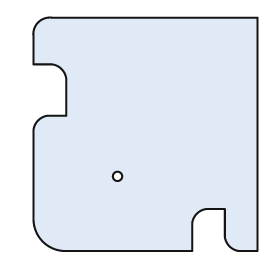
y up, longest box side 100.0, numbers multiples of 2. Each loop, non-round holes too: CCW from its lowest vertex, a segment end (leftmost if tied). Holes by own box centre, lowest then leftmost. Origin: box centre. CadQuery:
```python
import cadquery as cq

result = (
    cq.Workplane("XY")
    .moveTo(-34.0, -50.0)
    .lineTo(20.0, -50.0)
    .lineTo(20.0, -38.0)
    .threePointArc((22.0, -34.0), (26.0, -32.0))
    .lineTo(34.0, -32.0)
    .lineTo(34.0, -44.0)
    .threePointArc((36.0, -48.0), (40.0, -50.0))
    .lineTo(48.0, -50.0)
    .lineTo(48.0, 50.0)
    .lineTo(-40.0, 50.0)
    .threePointArc((-46.0, 48.0), (-48.0, 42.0))
    .lineTo(-48.0, 30.0)
    .lineTo(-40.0, 30.0)
    .threePointArc((-36.0, 28.0), (-34.0, 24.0))
    .lineTo(-34.0, 8.0)
    .lineTo(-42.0, 8.0)
    .threePointArc((-46.0, 6.0), (-48.0, 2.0))
    .lineTo(-48.0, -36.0)
    .threePointArc((-44.0, -46.0), (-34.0, -50.0))
    .close()
    .moveTo(-12.0, -18.0)
    .circle(2.0)
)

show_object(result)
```